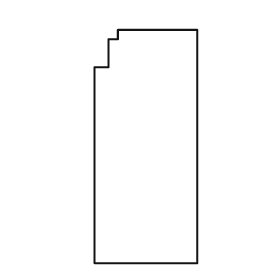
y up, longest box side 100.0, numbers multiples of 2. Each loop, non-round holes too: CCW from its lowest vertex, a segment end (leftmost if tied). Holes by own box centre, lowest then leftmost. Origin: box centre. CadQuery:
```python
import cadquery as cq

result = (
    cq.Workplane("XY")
    .moveTo(-22.0, -50.0)
    .lineTo(22.0, -50.0)
    .lineTo(22.0, 50.0)
    .lineTo(-12.0, 50.0)
    .lineTo(-12.0, 46.0)
    .lineTo(-16.0, 46.0)
    .lineTo(-16.0, 34.0)
    .lineTo(-22.0, 34.0)
    .close()
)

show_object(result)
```